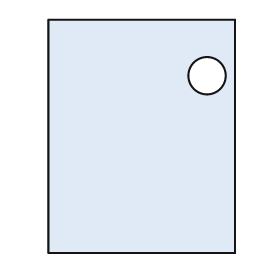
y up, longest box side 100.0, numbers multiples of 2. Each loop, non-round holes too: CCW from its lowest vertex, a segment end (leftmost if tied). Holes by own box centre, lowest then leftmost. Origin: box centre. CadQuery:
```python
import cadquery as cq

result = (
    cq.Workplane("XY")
    .moveTo(-40.0, -50.0)
    .lineTo(40.0, -50.0)
    .lineTo(40.0, 50.0)
    .lineTo(-40.0, 50.0)
    .close()
    .moveTo(28.0, 26.0)
    .circle(8.0)
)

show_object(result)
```